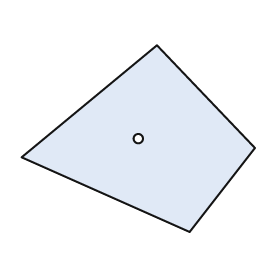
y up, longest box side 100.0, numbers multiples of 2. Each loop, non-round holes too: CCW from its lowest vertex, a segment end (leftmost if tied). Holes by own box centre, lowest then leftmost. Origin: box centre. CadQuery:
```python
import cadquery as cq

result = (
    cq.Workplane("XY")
    .moveTo(22.0, -40.0)
    .lineTo(50.0, -4.0)
    .lineTo(8.0, 40.0)
    .lineTo(-50.0, -8.0)
    .close()
    .moveTo(0.0, 0.0)
    .circle(2.0)
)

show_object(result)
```